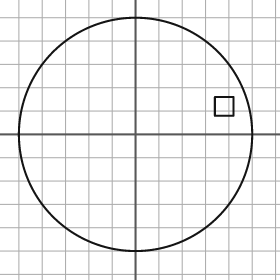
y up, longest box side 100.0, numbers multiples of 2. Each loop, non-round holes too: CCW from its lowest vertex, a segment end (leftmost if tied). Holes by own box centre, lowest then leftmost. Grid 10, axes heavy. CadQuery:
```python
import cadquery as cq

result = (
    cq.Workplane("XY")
    .moveTo(0.0, 0.0)
    .circle(50.0)
    .moveTo(34.0, 8.0)
    .lineTo(42.0, 8.0)
    .lineTo(42.0, 16.0)
    .lineTo(34.0, 16.0)
    .close()
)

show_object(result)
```